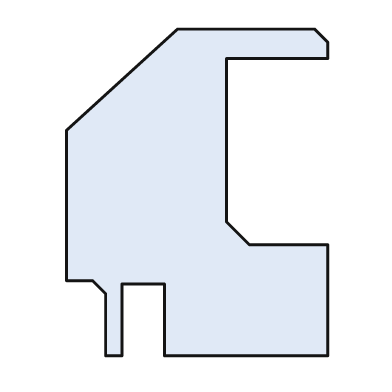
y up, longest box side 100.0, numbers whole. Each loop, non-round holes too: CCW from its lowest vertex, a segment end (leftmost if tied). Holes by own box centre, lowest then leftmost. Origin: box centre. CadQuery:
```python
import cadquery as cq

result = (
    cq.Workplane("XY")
    .moveTo(-28.0, -50.0)
    .lineTo(-23.0, -50.0)
    .lineTo(-23.0, -28.0)
    .lineTo(-10.0, -28.0)
    .lineTo(-10.0, -50.0)
    .lineTo(40.0, -50.0)
    .lineTo(40.0, -16.0)
    .lineTo(16.0, -16.0)
    .lineTo(9.0, -9.0)
    .lineTo(9.0, 41.0)
    .lineTo(40.0, 41.0)
    .lineTo(40.0, 46.0)
    .lineTo(36.0, 50.0)
    .lineTo(-6.0, 50.0)
    .lineTo(-40.0, 19.0)
    .lineTo(-40.0, -27.0)
    .lineTo(-32.0, -27.0)
    .lineTo(-28.0, -31.0)
    .close()
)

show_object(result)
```